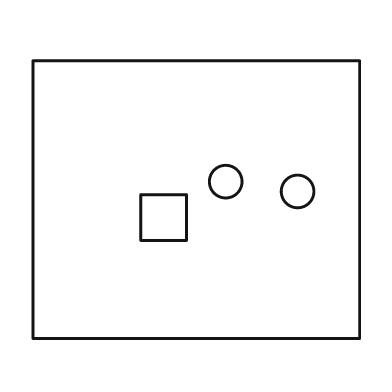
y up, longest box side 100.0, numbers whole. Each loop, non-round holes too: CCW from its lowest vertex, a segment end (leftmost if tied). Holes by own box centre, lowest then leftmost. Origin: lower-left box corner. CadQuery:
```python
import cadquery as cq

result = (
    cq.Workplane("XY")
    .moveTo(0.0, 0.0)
    .lineTo(100.0, 0.0)
    .lineTo(100.0, 85.0)
    .lineTo(0.0, 85.0)
    .close()
    .moveTo(33.0, 30.0)
    .lineTo(47.0, 30.0)
    .lineTo(47.0, 44.0)
    .lineTo(33.0, 44.0)
    .close()
    .moveTo(81.0, 45.0)
    .circle(5.0)
    .moveTo(59.0, 48.0)
    .circle(5.0)
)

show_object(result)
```